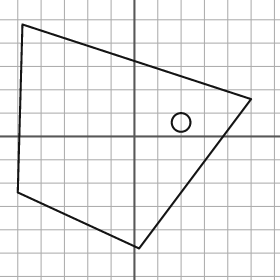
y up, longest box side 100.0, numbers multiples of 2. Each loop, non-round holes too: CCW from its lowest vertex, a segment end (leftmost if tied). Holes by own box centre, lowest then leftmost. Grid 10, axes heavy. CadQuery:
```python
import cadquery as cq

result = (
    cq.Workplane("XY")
    .moveTo(2.0, -48.0)
    .lineTo(50.0, 16.0)
    .lineTo(-48.0, 48.0)
    .lineTo(-50.0, -24.0)
    .close()
    .moveTo(20.0, 6.0)
    .circle(4.0)
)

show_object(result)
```